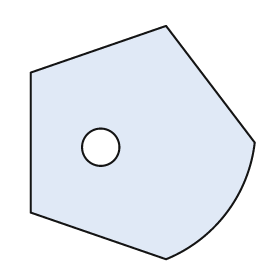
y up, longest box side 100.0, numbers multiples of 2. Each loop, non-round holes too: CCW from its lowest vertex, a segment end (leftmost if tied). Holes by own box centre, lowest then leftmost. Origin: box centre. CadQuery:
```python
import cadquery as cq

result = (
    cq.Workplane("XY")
    .moveTo(10.0, -50.0)
    .threePointArc((36.0, -30.0), (48.0, 0.0))
    .lineTo(10.0, 50.0)
    .lineTo(-48.0, 30.0)
    .lineTo(-48.0, -30.0)
    .close()
    .moveTo(-18.0, -2.0)
    .circle(8.0)
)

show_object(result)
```